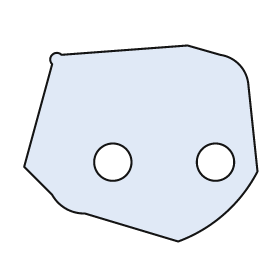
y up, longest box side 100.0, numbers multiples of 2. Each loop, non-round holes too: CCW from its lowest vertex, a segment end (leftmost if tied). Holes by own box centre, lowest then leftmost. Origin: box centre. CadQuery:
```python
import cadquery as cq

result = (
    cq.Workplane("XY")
    .moveTo(16.0, -42.0)
    .threePointArc((36.0, -30.0), (50.0, -12.0))
    .lineTo(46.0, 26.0)
    .threePointArc((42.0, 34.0), (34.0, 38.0))
    .lineTo(20.0, 42.0)
    .lineTo(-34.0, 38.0)
    .threePointArc((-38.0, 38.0), (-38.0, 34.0))
    .lineTo(-50.0, -10.0)
    .lineTo(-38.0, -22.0)
    .threePointArc((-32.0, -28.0), (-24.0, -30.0))
    .close()
    .moveTo(-12.0, -8.0)
    .circle(8.0)
    .moveTo(32.0, -8.0)
    .circle(8.0)
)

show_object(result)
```